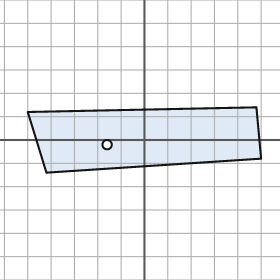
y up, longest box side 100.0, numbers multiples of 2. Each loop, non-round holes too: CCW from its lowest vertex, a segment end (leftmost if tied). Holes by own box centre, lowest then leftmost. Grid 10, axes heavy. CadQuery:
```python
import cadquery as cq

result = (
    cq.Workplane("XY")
    .moveTo(-42.0, -14.0)
    .lineTo(50.0, -8.0)
    .lineTo(48.0, 14.0)
    .lineTo(-50.0, 12.0)
    .close()
    .moveTo(-16.0, -2.0)
    .circle(2.0)
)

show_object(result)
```